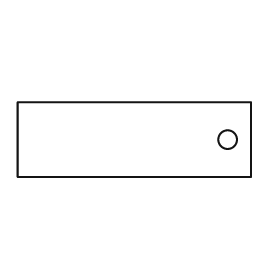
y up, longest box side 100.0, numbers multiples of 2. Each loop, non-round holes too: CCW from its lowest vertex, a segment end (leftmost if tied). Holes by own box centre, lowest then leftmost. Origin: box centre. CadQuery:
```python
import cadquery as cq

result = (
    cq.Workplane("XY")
    .moveTo(-50.0, -16.0)
    .lineTo(50.0, -16.0)
    .lineTo(50.0, 16.0)
    .lineTo(-50.0, 16.0)
    .close()
    .moveTo(40.0, 0.0)
    .circle(4.0)
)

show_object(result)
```